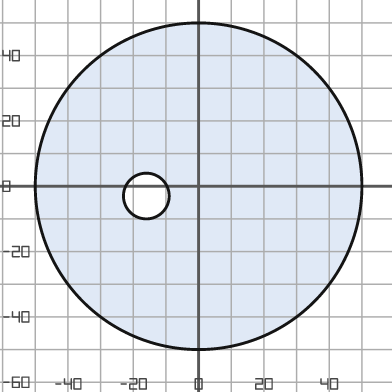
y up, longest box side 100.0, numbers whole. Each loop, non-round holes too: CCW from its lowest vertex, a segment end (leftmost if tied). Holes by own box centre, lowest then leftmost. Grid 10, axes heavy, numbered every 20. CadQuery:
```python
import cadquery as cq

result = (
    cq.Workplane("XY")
    .moveTo(0.0, 0.0)
    .circle(50.0)
    .moveTo(-16.0, -3.0)
    .circle(7.0)
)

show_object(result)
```